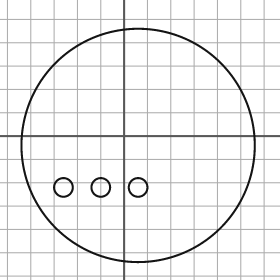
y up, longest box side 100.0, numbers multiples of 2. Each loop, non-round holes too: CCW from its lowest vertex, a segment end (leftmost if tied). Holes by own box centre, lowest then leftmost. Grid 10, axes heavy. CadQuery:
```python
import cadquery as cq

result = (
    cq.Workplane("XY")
    .moveTo(6.0, -4.0)
    .circle(50.0)
    .moveTo(-26.0, -22.0)
    .circle(4.0)
    .moveTo(-10.0, -22.0)
    .circle(4.0)
    .moveTo(6.0, -22.0)
    .circle(4.0)
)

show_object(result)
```